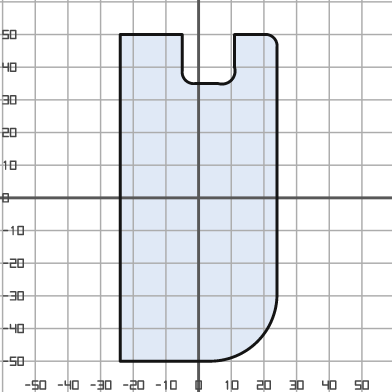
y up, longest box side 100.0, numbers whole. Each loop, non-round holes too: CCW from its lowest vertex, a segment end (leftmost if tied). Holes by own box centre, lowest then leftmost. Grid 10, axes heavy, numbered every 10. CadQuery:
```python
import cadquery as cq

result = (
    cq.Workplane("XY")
    .moveTo(-24.0, -50.0)
    .lineTo(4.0, -50.0)
    .threePointArc((18.0, -44.0), (24.0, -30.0))
    .lineTo(24.0, 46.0)
    .threePointArc((23.0, 49.0), (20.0, 50.0))
    .lineTo(11.0, 50.0)
    .lineTo(11.0, 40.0)
    .threePointArc((10.0, 36.0), (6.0, 35.0))
    .lineTo(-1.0, 35.0)
    .threePointArc((-4.0, 36.0), (-5.0, 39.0))
    .lineTo(-5.0, 50.0)
    .lineTo(-24.0, 50.0)
    .close()
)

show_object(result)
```